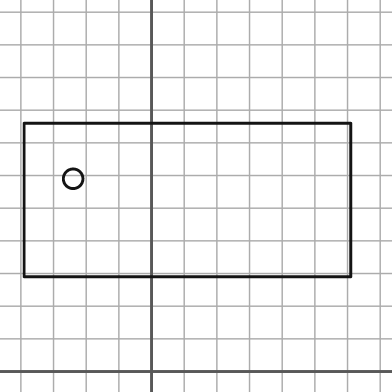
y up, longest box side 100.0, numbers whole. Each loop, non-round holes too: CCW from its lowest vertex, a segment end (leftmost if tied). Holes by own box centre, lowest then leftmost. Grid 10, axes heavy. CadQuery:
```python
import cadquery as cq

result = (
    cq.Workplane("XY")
    .moveTo(-39.0, 29.0)
    .lineTo(61.0, 29.0)
    .lineTo(61.0, 76.0)
    .lineTo(-39.0, 76.0)
    .close()
    .moveTo(-24.0, 59.0)
    .circle(3.0)
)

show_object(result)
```